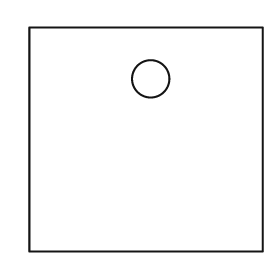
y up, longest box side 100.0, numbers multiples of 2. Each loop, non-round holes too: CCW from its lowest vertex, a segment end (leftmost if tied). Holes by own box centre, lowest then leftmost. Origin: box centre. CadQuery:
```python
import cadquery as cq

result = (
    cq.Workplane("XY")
    .moveTo(-50.0, -48.0)
    .lineTo(50.0, -48.0)
    .lineTo(50.0, 48.0)
    .lineTo(-50.0, 48.0)
    .close()
    .moveTo(2.0, 26.0)
    .circle(8.0)
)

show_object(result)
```